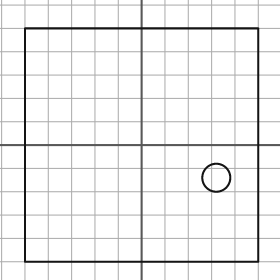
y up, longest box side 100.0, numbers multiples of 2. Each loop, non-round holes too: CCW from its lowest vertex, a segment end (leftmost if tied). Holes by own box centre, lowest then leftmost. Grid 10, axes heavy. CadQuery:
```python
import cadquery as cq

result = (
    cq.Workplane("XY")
    .moveTo(-50.0, -50.0)
    .lineTo(50.0, -50.0)
    .lineTo(50.0, 50.0)
    .lineTo(-50.0, 50.0)
    .close()
    .moveTo(32.0, -14.0)
    .circle(6.0)
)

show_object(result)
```